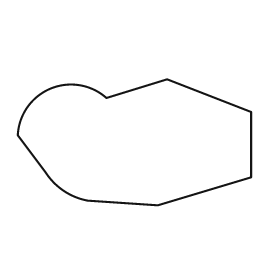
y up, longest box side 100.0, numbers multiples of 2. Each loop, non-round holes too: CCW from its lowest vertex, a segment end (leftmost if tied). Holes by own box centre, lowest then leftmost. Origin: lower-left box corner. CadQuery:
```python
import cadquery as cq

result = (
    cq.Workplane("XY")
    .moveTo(60.0, 0.0)
    .lineTo(100.0, 12.0)
    .lineTo(100.0, 40.0)
    .lineTo(64.0, 54.0)
    .lineTo(38.0, 46.0)
    .threePointArc((14.0, 50.0), (0.0, 30.0))
    .lineTo(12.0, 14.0)
    .threePointArc((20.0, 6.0), (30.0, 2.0))
    .close()
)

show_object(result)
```